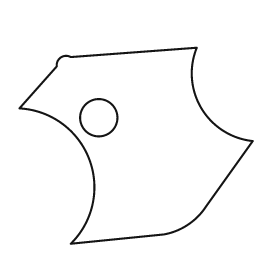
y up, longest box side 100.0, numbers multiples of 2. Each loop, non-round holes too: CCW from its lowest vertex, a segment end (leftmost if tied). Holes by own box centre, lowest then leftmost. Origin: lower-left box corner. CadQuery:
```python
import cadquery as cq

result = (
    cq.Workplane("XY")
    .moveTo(22.0, 0.0)
    .lineTo(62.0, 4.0)
    .threePointArc((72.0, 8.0), (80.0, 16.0))
    .lineTo(100.0, 44.0)
    .threePointArc((78.0, 58.0), (76.0, 84.0))
    .lineTo(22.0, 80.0)
    .threePointArc((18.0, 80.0), (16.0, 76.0))
    .lineTo(0.0, 58.0)
    .threePointArc((30.0, 36.0), (22.0, 0.0))
    .close()
    .moveTo(34.0, 54.0)
    .circle(8.0)
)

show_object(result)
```